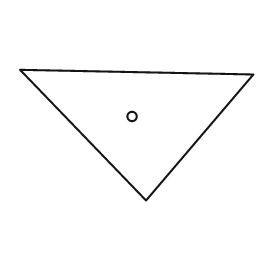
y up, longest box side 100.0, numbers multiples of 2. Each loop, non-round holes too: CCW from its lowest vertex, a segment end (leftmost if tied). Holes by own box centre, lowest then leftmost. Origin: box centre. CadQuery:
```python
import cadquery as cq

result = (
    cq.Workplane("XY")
    .moveTo(4.0, -28.0)
    .lineTo(50.0, 26.0)
    .lineTo(-50.0, 28.0)
    .close()
    .moveTo(-2.0, 8.0)
    .circle(2.0)
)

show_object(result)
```